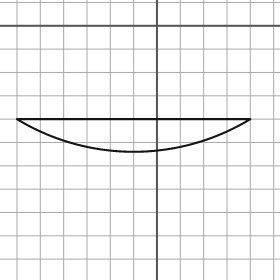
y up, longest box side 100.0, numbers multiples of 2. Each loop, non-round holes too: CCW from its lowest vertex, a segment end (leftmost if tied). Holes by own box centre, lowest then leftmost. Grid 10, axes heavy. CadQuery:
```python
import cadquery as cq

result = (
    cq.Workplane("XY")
    .moveTo(-60.0, -40.0)
    .threePointArc((-10.0, -54.0), (40.0, -40.0))
    .close()
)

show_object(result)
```